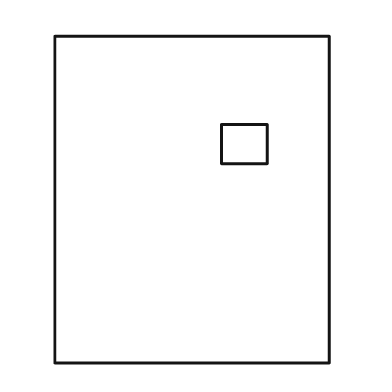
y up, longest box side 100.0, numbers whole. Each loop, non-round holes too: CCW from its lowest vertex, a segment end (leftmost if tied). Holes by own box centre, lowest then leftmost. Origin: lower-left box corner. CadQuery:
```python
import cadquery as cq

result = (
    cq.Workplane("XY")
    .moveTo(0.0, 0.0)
    .lineTo(84.0, 0.0)
    .lineTo(84.0, 100.0)
    .lineTo(0.0, 100.0)
    .close()
    .moveTo(51.0, 61.0)
    .lineTo(65.0, 61.0)
    .lineTo(65.0, 73.0)
    .lineTo(51.0, 73.0)
    .close()
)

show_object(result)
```